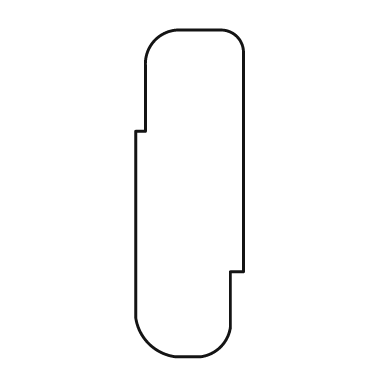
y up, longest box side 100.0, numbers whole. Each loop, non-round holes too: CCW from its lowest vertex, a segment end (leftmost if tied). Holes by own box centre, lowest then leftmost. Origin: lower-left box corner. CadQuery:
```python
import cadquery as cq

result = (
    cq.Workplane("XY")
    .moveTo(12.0, 0.0)
    .lineTo(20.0, 0.0)
    .threePointArc((26.0, 3.0), (29.0, 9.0))
    .lineTo(29.0, 26.0)
    .lineTo(33.0, 26.0)
    .lineTo(33.0, 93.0)
    .threePointArc((31.0, 98.0), (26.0, 100.0))
    .lineTo(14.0, 100.0)
    .threePointArc((6.0, 97.0), (3.0, 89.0))
    .lineTo(3.0, 69.0)
    .lineTo(0.0, 69.0)
    .lineTo(0.0, 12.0)
    .threePointArc((4.0, 4.0), (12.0, 0.0))
    .close()
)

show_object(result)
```